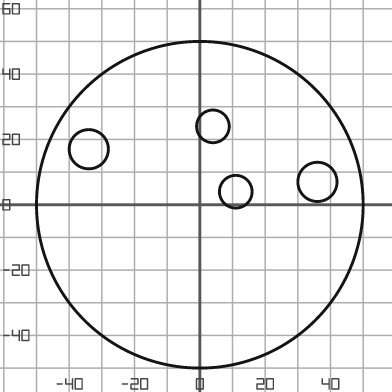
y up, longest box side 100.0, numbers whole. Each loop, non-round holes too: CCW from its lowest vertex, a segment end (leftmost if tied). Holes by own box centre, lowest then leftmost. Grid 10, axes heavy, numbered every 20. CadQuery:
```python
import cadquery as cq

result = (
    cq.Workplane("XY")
    .moveTo(0.0, 0.0)
    .circle(50.0)
    .moveTo(11.0, 4.0)
    .circle(5.0)
    .moveTo(36.0, 7.0)
    .circle(6.0)
    .moveTo(-34.0, 17.0)
    .circle(6.0)
    .moveTo(4.0, 24.0)
    .circle(5.0)
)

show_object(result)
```